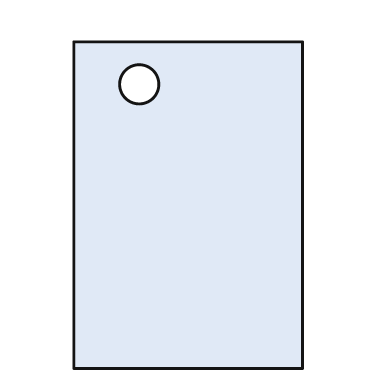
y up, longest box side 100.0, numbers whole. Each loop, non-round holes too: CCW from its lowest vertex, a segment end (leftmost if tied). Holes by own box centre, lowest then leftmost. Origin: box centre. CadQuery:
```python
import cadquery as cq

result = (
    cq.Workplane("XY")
    .moveTo(-35.0, -50.0)
    .lineTo(35.0, -50.0)
    .lineTo(35.0, 50.0)
    .lineTo(-35.0, 50.0)
    .close()
    .moveTo(-15.0, 37.0)
    .circle(6.0)
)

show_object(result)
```